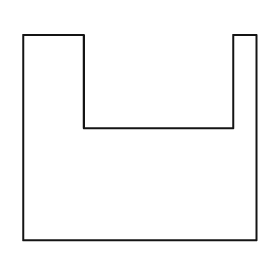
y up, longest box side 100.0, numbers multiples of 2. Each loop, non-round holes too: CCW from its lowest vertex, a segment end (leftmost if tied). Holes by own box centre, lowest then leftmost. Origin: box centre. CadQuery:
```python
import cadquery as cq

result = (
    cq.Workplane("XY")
    .moveTo(-50.0, -44.0)
    .lineTo(50.0, -44.0)
    .lineTo(50.0, 44.0)
    .lineTo(40.0, 44.0)
    .lineTo(40.0, 4.0)
    .lineTo(-24.0, 4.0)
    .lineTo(-24.0, 44.0)
    .lineTo(-50.0, 44.0)
    .close()
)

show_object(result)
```